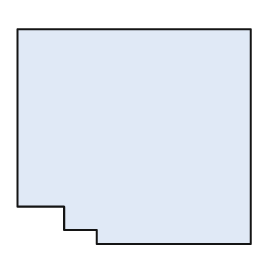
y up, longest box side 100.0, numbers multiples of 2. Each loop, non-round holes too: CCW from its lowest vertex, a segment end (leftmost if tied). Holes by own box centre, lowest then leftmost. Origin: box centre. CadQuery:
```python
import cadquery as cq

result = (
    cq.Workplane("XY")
    .moveTo(-16.0, -46.0)
    .lineTo(50.0, -46.0)
    .lineTo(50.0, 46.0)
    .lineTo(-50.0, 46.0)
    .lineTo(-50.0, -30.0)
    .lineTo(-30.0, -30.0)
    .lineTo(-30.0, -40.0)
    .lineTo(-16.0, -40.0)
    .close()
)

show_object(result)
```